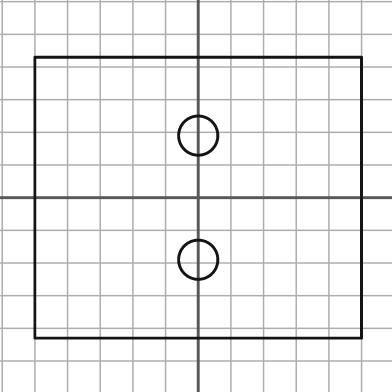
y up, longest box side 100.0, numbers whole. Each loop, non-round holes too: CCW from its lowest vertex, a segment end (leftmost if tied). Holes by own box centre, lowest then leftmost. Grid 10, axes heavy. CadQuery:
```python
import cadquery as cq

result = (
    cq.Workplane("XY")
    .moveTo(-50.0, -43.0)
    .lineTo(50.0, -43.0)
    .lineTo(50.0, 43.0)
    .lineTo(-50.0, 43.0)
    .close()
    .moveTo(0.0, -19.0)
    .circle(6.0)
    .moveTo(0.0, 19.0)
    .circle(6.0)
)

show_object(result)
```